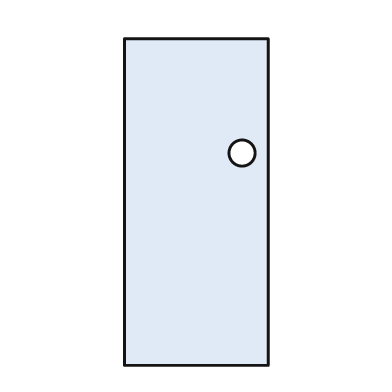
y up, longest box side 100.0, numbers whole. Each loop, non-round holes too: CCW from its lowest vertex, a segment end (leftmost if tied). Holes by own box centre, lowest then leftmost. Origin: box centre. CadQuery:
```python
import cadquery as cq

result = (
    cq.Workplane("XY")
    .moveTo(-22.0, -50.0)
    .lineTo(22.0, -50.0)
    .lineTo(22.0, 50.0)
    .lineTo(-22.0, 50.0)
    .close()
    .moveTo(14.0, 15.0)
    .circle(4.0)
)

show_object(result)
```